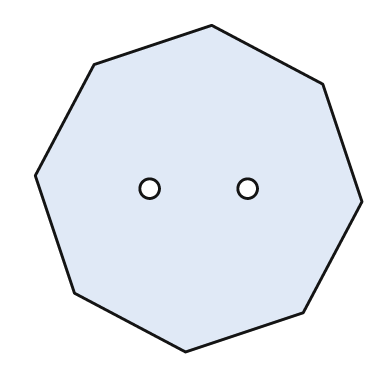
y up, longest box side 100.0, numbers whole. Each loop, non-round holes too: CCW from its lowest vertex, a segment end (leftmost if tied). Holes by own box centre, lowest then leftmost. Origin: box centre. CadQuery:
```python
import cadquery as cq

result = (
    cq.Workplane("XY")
    .moveTo(-4.0, -50.0)
    .lineTo(32.0, -38.0)
    .lineTo(50.0, -4.0)
    .lineTo(38.0, 32.0)
    .lineTo(4.0, 50.0)
    .lineTo(-32.0, 38.0)
    .lineTo(-50.0, 4.0)
    .lineTo(-38.0, -32.0)
    .close()
    .moveTo(-15.0, 0.0)
    .circle(3.0)
    .moveTo(15.0, 0.0)
    .circle(3.0)
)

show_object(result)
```